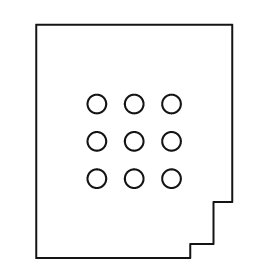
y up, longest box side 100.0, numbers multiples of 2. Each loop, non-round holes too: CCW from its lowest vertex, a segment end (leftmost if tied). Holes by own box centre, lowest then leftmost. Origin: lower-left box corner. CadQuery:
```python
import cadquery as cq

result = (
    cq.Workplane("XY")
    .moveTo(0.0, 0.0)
    .lineTo(66.0, 0.0)
    .lineTo(66.0, 6.0)
    .lineTo(76.0, 6.0)
    .lineTo(76.0, 24.0)
    .lineTo(84.0, 24.0)
    .lineTo(84.0, 100.0)
    .lineTo(0.0, 100.0)
    .close()
    .moveTo(26.0, 34.0)
    .circle(4.0)
    .moveTo(42.0, 34.0)
    .circle(4.0)
    .moveTo(58.0, 34.0)
    .circle(4.0)
    .moveTo(26.0, 50.0)
    .circle(4.0)
    .moveTo(42.0, 50.0)
    .circle(4.0)
    .moveTo(58.0, 50.0)
    .circle(4.0)
    .moveTo(26.0, 66.0)
    .circle(4.0)
    .moveTo(42.0, 66.0)
    .circle(4.0)
    .moveTo(58.0, 66.0)
    .circle(4.0)
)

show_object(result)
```